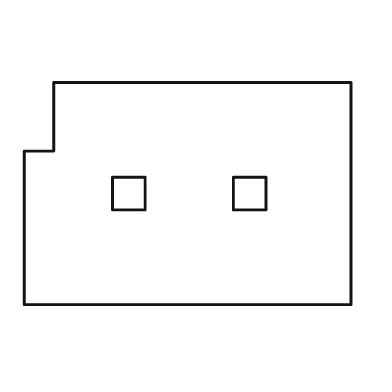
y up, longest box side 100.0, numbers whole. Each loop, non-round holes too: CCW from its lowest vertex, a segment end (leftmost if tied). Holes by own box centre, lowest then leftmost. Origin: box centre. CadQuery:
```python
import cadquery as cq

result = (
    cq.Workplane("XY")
    .moveTo(-50.0, -34.0)
    .lineTo(50.0, -34.0)
    .lineTo(50.0, 34.0)
    .lineTo(-41.0, 34.0)
    .lineTo(-41.0, 13.0)
    .lineTo(-50.0, 13.0)
    .close()
    .moveTo(-23.0, -5.0)
    .lineTo(-13.0, -5.0)
    .lineTo(-13.0, 5.0)
    .lineTo(-23.0, 5.0)
    .close()
    .moveTo(14.0, -5.0)
    .lineTo(24.0, -5.0)
    .lineTo(24.0, 5.0)
    .lineTo(14.0, 5.0)
    .close()
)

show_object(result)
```